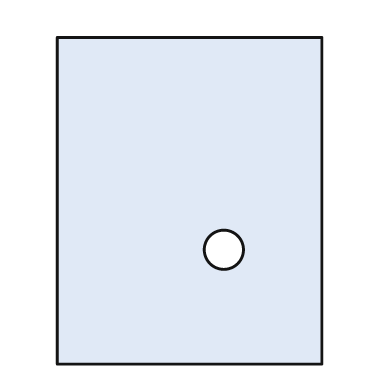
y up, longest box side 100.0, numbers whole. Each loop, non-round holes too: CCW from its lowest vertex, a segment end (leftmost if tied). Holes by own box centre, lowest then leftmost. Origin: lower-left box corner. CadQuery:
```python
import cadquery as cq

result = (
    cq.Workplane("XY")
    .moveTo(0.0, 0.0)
    .lineTo(81.0, 0.0)
    .lineTo(81.0, 100.0)
    .lineTo(0.0, 100.0)
    .close()
    .moveTo(51.0, 35.0)
    .circle(6.0)
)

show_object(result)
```